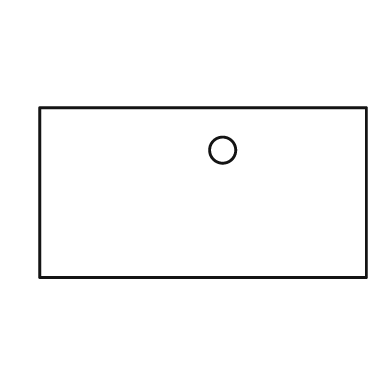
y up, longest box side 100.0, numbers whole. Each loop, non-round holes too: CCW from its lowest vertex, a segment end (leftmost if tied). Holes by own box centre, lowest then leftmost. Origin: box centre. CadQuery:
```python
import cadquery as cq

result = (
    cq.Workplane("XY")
    .moveTo(-50.0, -26.0)
    .lineTo(50.0, -26.0)
    .lineTo(50.0, 26.0)
    .lineTo(-50.0, 26.0)
    .close()
    .moveTo(6.0, 13.0)
    .circle(4.0)
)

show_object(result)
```